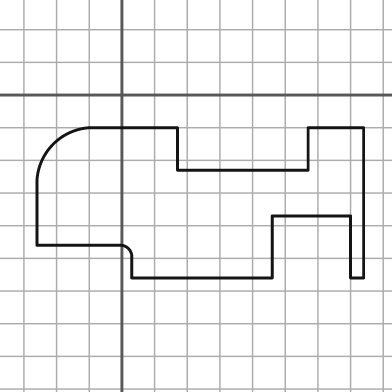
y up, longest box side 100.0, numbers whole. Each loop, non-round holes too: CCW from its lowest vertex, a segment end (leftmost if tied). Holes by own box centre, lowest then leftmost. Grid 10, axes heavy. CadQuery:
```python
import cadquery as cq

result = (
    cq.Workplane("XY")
    .moveTo(3.0, -56.0)
    .lineTo(46.0, -56.0)
    .lineTo(46.0, -37.0)
    .lineTo(70.0, -37.0)
    .lineTo(70.0, -56.0)
    .lineTo(74.0, -56.0)
    .lineTo(74.0, -10.0)
    .lineTo(57.0, -10.0)
    .lineTo(57.0, -23.0)
    .lineTo(17.0, -23.0)
    .lineTo(17.0, -10.0)
    .lineTo(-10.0, -10.0)
    .threePointArc((-21.0, -15.0), (-26.0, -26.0))
    .lineTo(-26.0, -46.0)
    .lineTo(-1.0, -46.0)
    .threePointArc((2.0, -47.0), (3.0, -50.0))
    .close()
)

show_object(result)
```